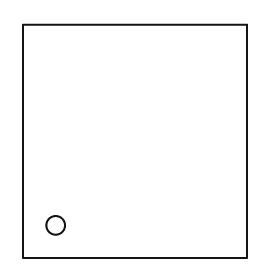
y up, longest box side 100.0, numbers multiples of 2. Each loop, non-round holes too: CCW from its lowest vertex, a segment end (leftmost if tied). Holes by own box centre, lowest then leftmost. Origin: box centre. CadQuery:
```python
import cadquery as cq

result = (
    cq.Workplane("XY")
    .moveTo(-48.0, -50.0)
    .lineTo(48.0, -50.0)
    .lineTo(48.0, 50.0)
    .lineTo(-48.0, 50.0)
    .close()
    .moveTo(-34.0, -36.0)
    .circle(4.0)
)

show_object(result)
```